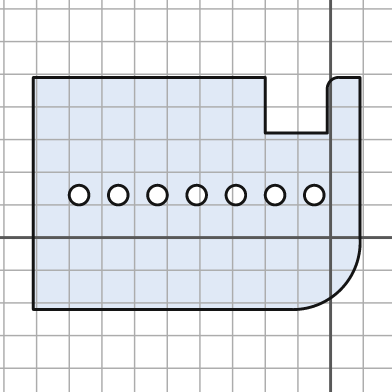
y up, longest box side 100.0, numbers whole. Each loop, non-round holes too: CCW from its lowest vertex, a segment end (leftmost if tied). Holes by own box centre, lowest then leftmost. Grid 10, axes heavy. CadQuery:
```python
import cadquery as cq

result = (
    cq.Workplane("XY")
    .moveTo(-91.0, -22.0)
    .lineTo(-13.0, -22.0)
    .threePointArc((3.0, -16.0), (9.0, 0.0))
    .lineTo(9.0, 49.0)
    .lineTo(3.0, 49.0)
    .threePointArc((0.0, 48.0), (-1.0, 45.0))
    .lineTo(-1.0, 32.0)
    .lineTo(-20.0, 32.0)
    .lineTo(-20.0, 49.0)
    .lineTo(-91.0, 49.0)
    .close()
    .moveTo(-77.0, 13.0)
    .circle(3.0)
    .moveTo(-65.0, 13.0)
    .circle(3.0)
    .moveTo(-53.0, 13.0)
    .circle(3.0)
    .moveTo(-41.0, 13.0)
    .circle(3.0)
    .moveTo(-29.0, 13.0)
    .circle(3.0)
    .moveTo(-17.0, 13.0)
    .circle(3.0)
    .moveTo(-5.0, 13.0)
    .circle(3.0)
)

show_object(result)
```